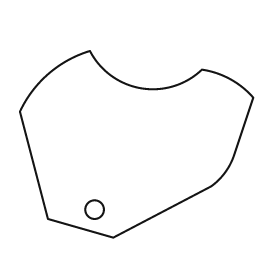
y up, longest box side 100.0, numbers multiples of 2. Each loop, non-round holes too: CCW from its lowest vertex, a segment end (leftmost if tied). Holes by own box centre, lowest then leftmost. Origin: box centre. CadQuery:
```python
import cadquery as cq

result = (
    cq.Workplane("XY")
    .moveTo(-10.0, -40.0)
    .lineTo(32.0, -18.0)
    .threePointArc((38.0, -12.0), (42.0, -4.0))
    .lineTo(50.0, 20.0)
    .threePointArc((40.0, 28.0), (28.0, 32.0))
    .threePointArc((2.0, 24.0), (-20.0, 40.0))
    .threePointArc((-38.0, 30.0), (-50.0, 14.0))
    .lineTo(-38.0, -32.0)
    .close()
    .moveTo(-18.0, -28.0)
    .circle(4.0)
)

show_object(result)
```